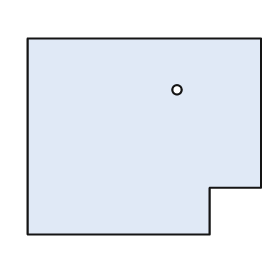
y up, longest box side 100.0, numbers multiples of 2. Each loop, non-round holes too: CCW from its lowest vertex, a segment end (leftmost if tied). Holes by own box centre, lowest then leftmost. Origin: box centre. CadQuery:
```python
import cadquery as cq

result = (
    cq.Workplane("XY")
    .moveTo(-50.0, -42.0)
    .lineTo(28.0, -42.0)
    .lineTo(28.0, -22.0)
    .lineTo(50.0, -22.0)
    .lineTo(50.0, 42.0)
    .lineTo(-50.0, 42.0)
    .close()
    .moveTo(14.0, 20.0)
    .circle(2.0)
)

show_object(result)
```